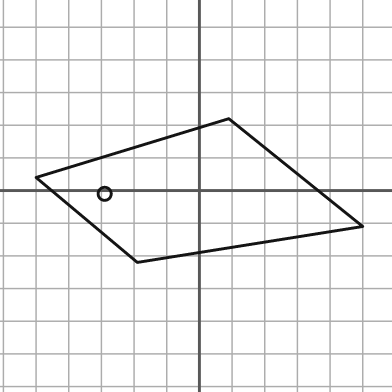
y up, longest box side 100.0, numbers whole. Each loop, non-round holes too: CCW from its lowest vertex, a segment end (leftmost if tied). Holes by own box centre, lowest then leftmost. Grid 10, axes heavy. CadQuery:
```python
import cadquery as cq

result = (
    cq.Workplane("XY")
    .moveTo(-19.0, -22.0)
    .lineTo(50.0, -11.0)
    .lineTo(9.0, 22.0)
    .lineTo(-50.0, 4.0)
    .close()
    .moveTo(-29.0, -1.0)
    .circle(2.0)
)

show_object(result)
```